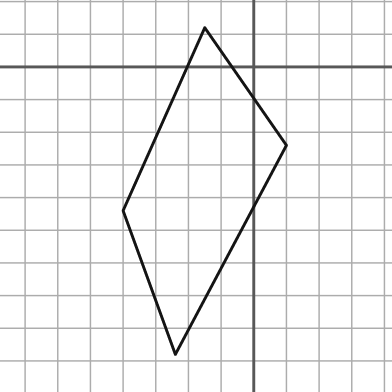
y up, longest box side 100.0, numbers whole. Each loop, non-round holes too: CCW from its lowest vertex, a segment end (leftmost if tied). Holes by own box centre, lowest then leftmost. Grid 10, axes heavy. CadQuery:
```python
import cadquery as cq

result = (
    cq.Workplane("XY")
    .moveTo(-24.0, -88.0)
    .lineTo(10.0, -24.0)
    .lineTo(-15.0, 12.0)
    .lineTo(-40.0, -44.0)
    .close()
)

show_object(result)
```